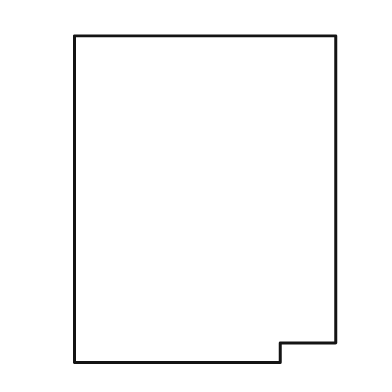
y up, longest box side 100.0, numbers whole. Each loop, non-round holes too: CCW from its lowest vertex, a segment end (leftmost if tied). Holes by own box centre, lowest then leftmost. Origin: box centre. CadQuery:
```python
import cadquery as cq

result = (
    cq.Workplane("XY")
    .moveTo(-40.0, -50.0)
    .lineTo(23.0, -50.0)
    .lineTo(23.0, -44.0)
    .lineTo(40.0, -44.0)
    .lineTo(40.0, 50.0)
    .lineTo(-40.0, 50.0)
    .close()
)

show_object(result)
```